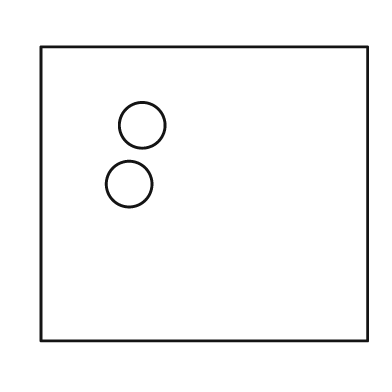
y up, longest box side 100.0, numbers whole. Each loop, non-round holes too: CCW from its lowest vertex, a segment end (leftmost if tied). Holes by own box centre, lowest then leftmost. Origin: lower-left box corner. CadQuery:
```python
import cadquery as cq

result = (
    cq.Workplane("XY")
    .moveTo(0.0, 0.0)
    .lineTo(100.0, 0.0)
    .lineTo(100.0, 90.0)
    .lineTo(0.0, 90.0)
    .close()
    .moveTo(27.0, 48.0)
    .circle(7.0)
    .moveTo(31.0, 66.0)
    .circle(7.0)
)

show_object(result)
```